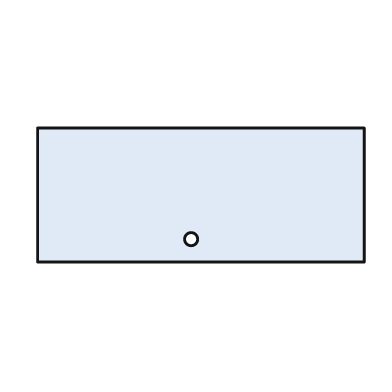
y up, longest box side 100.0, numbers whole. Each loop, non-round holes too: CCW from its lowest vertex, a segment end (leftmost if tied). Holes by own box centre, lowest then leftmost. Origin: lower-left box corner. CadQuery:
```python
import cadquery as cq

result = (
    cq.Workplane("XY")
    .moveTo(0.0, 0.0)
    .lineTo(100.0, 0.0)
    .lineTo(100.0, 41.0)
    .lineTo(0.0, 41.0)
    .close()
    .moveTo(47.0, 7.0)
    .circle(2.0)
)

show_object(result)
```